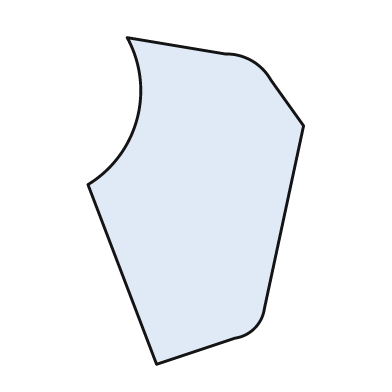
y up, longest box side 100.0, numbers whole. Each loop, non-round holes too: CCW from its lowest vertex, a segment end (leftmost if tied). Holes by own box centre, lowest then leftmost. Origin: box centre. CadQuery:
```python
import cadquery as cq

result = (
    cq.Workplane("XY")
    .moveTo(-12.0, -50.0)
    .lineTo(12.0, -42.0)
    .threePointArc((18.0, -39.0), (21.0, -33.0))
    .lineTo(33.0, 23.0)
    .lineTo(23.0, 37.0)
    .threePointArc((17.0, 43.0), (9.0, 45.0))
    .lineTo(-21.0, 50.0)
    .threePointArc((-18.0, 25.0), (-33.0, 5.0))
    .close()
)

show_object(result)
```